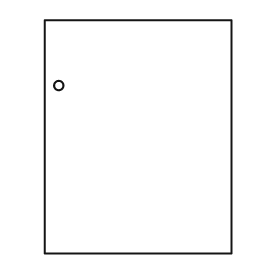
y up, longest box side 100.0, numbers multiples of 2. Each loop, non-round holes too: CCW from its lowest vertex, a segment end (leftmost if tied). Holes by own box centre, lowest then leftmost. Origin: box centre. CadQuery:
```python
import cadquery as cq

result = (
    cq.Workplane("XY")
    .moveTo(-40.0, -50.0)
    .lineTo(40.0, -50.0)
    .lineTo(40.0, 50.0)
    .lineTo(-40.0, 50.0)
    .close()
    .moveTo(-34.0, 22.0)
    .circle(2.0)
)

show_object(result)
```